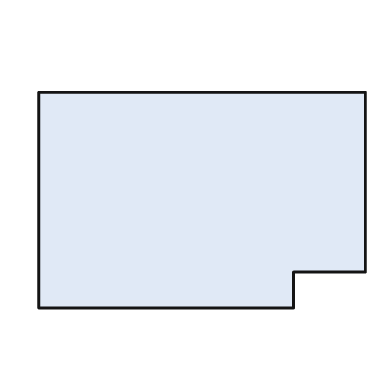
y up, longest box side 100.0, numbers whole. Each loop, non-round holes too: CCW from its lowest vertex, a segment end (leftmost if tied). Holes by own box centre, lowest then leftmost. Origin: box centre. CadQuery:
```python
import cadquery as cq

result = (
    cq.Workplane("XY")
    .moveTo(-50.0, -33.0)
    .lineTo(28.0, -33.0)
    .lineTo(28.0, -22.0)
    .lineTo(50.0, -22.0)
    .lineTo(50.0, 33.0)
    .lineTo(-50.0, 33.0)
    .close()
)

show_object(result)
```